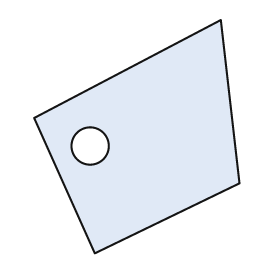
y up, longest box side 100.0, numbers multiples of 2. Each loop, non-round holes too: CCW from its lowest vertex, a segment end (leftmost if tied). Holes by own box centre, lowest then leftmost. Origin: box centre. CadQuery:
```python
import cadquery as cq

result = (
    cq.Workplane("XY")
    .moveTo(-18.0, -50.0)
    .lineTo(44.0, -20.0)
    .lineTo(36.0, 50.0)
    .lineTo(-44.0, 8.0)
    .close()
    .moveTo(-20.0, -4.0)
    .circle(8.0)
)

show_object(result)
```